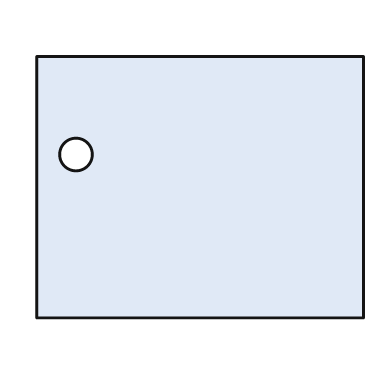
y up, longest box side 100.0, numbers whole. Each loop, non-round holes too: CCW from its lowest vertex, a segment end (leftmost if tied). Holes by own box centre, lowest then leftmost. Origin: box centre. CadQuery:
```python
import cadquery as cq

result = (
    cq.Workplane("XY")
    .moveTo(-50.0, -40.0)
    .lineTo(50.0, -40.0)
    .lineTo(50.0, 40.0)
    .lineTo(-50.0, 40.0)
    .close()
    .moveTo(-38.0, 10.0)
    .circle(5.0)
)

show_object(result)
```